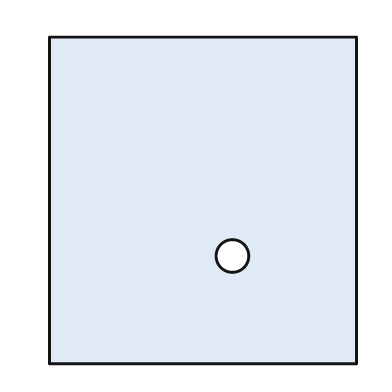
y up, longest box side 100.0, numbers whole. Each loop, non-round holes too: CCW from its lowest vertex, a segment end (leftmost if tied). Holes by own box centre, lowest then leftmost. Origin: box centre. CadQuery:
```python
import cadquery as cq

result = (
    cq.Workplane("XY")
    .moveTo(-47.0, -50.0)
    .lineTo(47.0, -50.0)
    .lineTo(47.0, 50.0)
    .lineTo(-47.0, 50.0)
    .close()
    .moveTo(9.0, -17.0)
    .circle(5.0)
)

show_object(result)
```